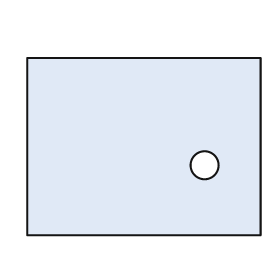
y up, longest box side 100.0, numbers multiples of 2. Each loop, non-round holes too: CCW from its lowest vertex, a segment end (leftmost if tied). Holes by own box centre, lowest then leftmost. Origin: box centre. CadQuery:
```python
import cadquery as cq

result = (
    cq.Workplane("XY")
    .moveTo(-50.0, -38.0)
    .lineTo(50.0, -38.0)
    .lineTo(50.0, 38.0)
    .lineTo(-50.0, 38.0)
    .close()
    .moveTo(26.0, -8.0)
    .circle(6.0)
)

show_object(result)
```